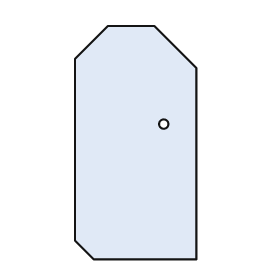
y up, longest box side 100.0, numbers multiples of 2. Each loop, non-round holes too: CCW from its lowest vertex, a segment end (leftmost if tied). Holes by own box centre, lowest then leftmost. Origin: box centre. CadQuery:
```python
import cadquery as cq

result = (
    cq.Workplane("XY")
    .moveTo(-18.0, -50.0)
    .lineTo(26.0, -50.0)
    .lineTo(26.0, 32.0)
    .lineTo(8.0, 50.0)
    .lineTo(-12.0, 50.0)
    .lineTo(-26.0, 36.0)
    .lineTo(-26.0, -42.0)
    .close()
    .moveTo(12.0, 8.0)
    .circle(2.0)
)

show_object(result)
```